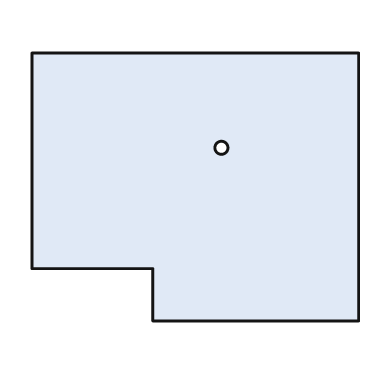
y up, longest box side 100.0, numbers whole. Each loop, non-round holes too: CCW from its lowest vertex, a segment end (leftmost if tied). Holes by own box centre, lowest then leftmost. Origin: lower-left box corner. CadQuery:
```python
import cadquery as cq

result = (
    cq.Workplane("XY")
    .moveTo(37.0, 0.0)
    .lineTo(100.0, 0.0)
    .lineTo(100.0, 82.0)
    .lineTo(0.0, 82.0)
    .lineTo(0.0, 16.0)
    .lineTo(37.0, 16.0)
    .close()
    .moveTo(58.0, 53.0)
    .circle(2.0)
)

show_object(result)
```